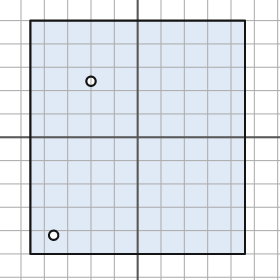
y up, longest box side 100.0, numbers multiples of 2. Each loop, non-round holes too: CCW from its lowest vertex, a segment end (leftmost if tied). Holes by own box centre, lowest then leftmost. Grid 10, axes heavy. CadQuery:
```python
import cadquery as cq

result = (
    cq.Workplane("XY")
    .moveTo(-46.0, -50.0)
    .lineTo(46.0, -50.0)
    .lineTo(46.0, 50.0)
    .lineTo(-46.0, 50.0)
    .close()
    .moveTo(-36.0, -42.0)
    .circle(2.0)
    .moveTo(-20.0, 24.0)
    .circle(2.0)
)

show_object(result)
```